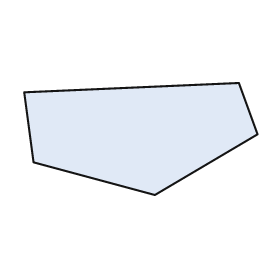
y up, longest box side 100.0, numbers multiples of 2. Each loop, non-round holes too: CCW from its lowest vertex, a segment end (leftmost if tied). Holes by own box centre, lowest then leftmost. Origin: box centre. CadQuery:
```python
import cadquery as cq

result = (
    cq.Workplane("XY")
    .moveTo(6.0, -24.0)
    .lineTo(50.0, 2.0)
    .lineTo(42.0, 24.0)
    .lineTo(-50.0, 20.0)
    .lineTo(-46.0, -10.0)
    .close()
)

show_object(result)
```